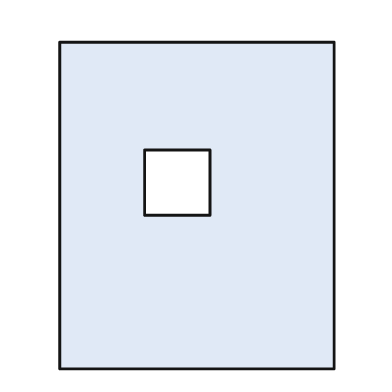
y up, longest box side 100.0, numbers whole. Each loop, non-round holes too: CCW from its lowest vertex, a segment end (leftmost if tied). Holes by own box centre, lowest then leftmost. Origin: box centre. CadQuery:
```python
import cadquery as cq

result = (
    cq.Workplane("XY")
    .moveTo(-42.0, -50.0)
    .lineTo(42.0, -50.0)
    .lineTo(42.0, 50.0)
    .lineTo(-42.0, 50.0)
    .close()
    .moveTo(-16.0, -3.0)
    .lineTo(4.0, -3.0)
    .lineTo(4.0, 17.0)
    .lineTo(-16.0, 17.0)
    .close()
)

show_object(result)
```